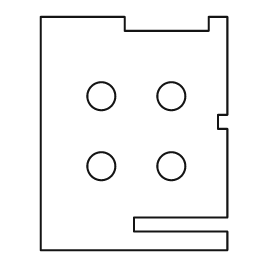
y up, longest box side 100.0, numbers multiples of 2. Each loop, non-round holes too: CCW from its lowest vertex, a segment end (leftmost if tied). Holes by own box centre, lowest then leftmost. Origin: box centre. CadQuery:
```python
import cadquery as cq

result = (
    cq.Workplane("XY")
    .moveTo(-40.0, -50.0)
    .lineTo(40.0, -50.0)
    .lineTo(40.0, -42.0)
    .lineTo(0.0, -42.0)
    .lineTo(0.0, -36.0)
    .lineTo(40.0, -36.0)
    .lineTo(40.0, 2.0)
    .lineTo(36.0, 2.0)
    .lineTo(36.0, 8.0)
    .lineTo(40.0, 8.0)
    .lineTo(40.0, 50.0)
    .lineTo(32.0, 50.0)
    .lineTo(32.0, 44.0)
    .lineTo(-4.0, 44.0)
    .lineTo(-4.0, 50.0)
    .lineTo(-40.0, 50.0)
    .close()
    .moveTo(-14.0, -14.0)
    .circle(6.0)
    .moveTo(16.0, -14.0)
    .circle(6.0)
    .moveTo(-14.0, 16.0)
    .circle(6.0)
    .moveTo(16.0, 16.0)
    .circle(6.0)
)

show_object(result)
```